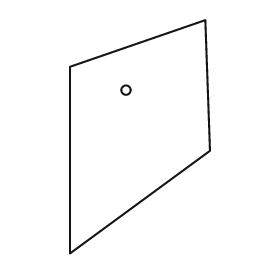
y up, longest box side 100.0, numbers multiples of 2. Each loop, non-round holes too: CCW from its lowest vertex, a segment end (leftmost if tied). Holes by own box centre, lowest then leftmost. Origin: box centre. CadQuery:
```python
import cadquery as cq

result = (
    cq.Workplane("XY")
    .moveTo(-30.0, -50.0)
    .lineTo(30.0, -6.0)
    .lineTo(28.0, 50.0)
    .lineTo(-30.0, 30.0)
    .close()
    .moveTo(-6.0, 20.0)
    .circle(2.0)
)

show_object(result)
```